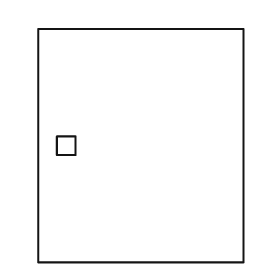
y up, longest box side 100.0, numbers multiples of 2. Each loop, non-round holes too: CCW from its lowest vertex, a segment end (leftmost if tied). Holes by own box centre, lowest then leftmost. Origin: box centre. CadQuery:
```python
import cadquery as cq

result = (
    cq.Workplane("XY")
    .moveTo(-44.0, -50.0)
    .lineTo(44.0, -50.0)
    .lineTo(44.0, 50.0)
    .lineTo(-44.0, 50.0)
    .close()
    .moveTo(-36.0, -4.0)
    .lineTo(-28.0, -4.0)
    .lineTo(-28.0, 4.0)
    .lineTo(-36.0, 4.0)
    .close()
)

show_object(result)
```